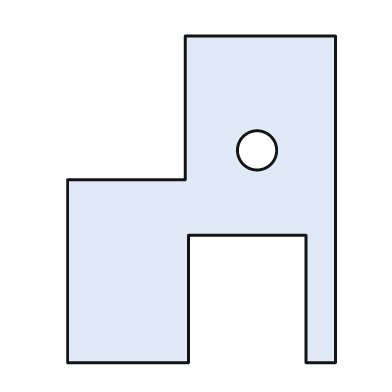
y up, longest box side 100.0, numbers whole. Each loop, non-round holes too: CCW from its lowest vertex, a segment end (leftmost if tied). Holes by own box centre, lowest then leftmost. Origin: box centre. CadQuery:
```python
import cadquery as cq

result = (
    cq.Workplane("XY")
    .moveTo(-41.0, -50.0)
    .lineTo(-4.0, -50.0)
    .lineTo(-4.0, -11.0)
    .lineTo(32.0, -11.0)
    .lineTo(32.0, -50.0)
    .lineTo(41.0, -50.0)
    .lineTo(41.0, 50.0)
    .lineTo(-5.0, 50.0)
    .lineTo(-5.0, 6.0)
    .lineTo(-41.0, 6.0)
    .close()
    .moveTo(17.0, 15.0)
    .circle(6.0)
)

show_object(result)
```